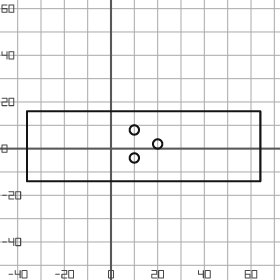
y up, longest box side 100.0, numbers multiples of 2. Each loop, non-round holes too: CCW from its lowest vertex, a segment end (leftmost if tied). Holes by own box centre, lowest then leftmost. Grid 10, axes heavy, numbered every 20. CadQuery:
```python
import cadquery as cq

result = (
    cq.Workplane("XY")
    .moveTo(-36.0, -14.0)
    .lineTo(64.0, -14.0)
    .lineTo(64.0, 16.0)
    .lineTo(-36.0, 16.0)
    .close()
    .moveTo(10.0, -4.0)
    .circle(2.0)
    .moveTo(20.0, 2.0)
    .circle(2.0)
    .moveTo(10.0, 8.0)
    .circle(2.0)
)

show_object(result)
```